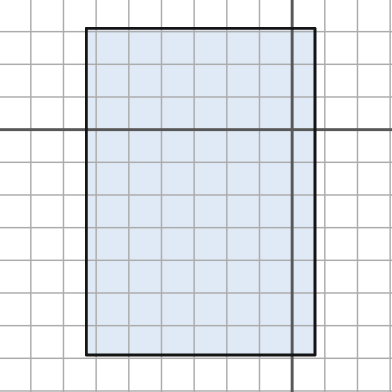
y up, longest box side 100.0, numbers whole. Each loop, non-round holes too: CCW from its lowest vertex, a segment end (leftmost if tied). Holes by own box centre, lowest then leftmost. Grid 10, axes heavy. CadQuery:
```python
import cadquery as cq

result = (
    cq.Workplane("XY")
    .moveTo(-63.0, -69.0)
    .lineTo(7.0, -69.0)
    .lineTo(7.0, 31.0)
    .lineTo(-63.0, 31.0)
    .close()
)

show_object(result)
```